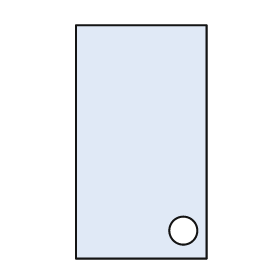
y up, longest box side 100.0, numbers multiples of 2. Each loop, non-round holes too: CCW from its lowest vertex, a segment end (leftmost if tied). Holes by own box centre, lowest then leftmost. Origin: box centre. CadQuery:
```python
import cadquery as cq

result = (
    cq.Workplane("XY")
    .moveTo(-28.0, -50.0)
    .lineTo(28.0, -50.0)
    .lineTo(28.0, 50.0)
    .lineTo(-28.0, 50.0)
    .close()
    .moveTo(18.0, -38.0)
    .circle(6.0)
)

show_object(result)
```